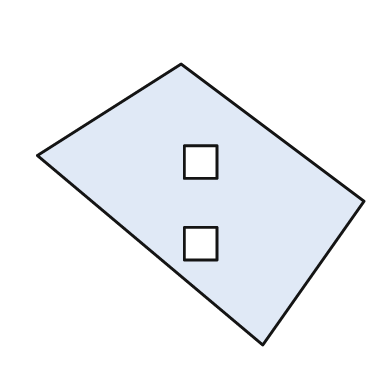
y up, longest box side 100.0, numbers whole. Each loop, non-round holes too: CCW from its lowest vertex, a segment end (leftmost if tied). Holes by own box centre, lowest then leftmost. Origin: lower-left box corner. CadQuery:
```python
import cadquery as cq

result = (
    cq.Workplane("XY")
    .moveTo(69.0, 0.0)
    .lineTo(100.0, 44.0)
    .lineTo(44.0, 86.0)
    .lineTo(0.0, 58.0)
    .close()
    .moveTo(45.0, 26.0)
    .lineTo(55.0, 26.0)
    .lineTo(55.0, 36.0)
    .lineTo(45.0, 36.0)
    .close()
    .moveTo(45.0, 51.0)
    .lineTo(55.0, 51.0)
    .lineTo(55.0, 61.0)
    .lineTo(45.0, 61.0)
    .close()
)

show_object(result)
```